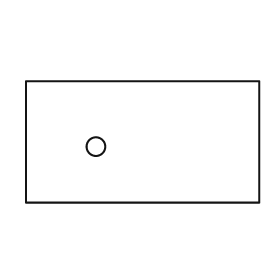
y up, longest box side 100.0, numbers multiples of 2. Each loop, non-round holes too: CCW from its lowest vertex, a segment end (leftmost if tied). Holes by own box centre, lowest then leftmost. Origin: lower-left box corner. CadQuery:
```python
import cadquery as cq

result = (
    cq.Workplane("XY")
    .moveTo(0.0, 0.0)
    .lineTo(100.0, 0.0)
    .lineTo(100.0, 52.0)
    .lineTo(0.0, 52.0)
    .close()
    .moveTo(30.0, 24.0)
    .circle(4.0)
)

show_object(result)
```